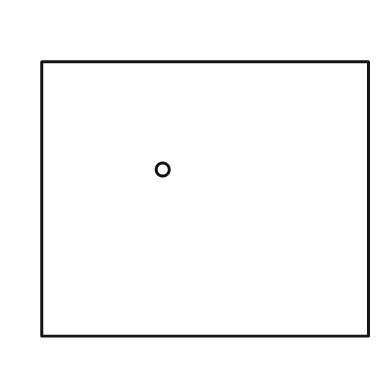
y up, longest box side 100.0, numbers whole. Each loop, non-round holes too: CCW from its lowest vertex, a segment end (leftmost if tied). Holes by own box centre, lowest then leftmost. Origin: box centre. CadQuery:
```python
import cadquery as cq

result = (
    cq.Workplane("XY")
    .moveTo(-50.0, -42.0)
    .lineTo(50.0, -42.0)
    .lineTo(50.0, 42.0)
    .lineTo(-50.0, 42.0)
    .close()
    .moveTo(-13.0, 9.0)
    .circle(2.0)
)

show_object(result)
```